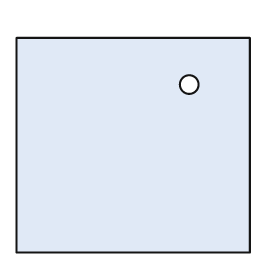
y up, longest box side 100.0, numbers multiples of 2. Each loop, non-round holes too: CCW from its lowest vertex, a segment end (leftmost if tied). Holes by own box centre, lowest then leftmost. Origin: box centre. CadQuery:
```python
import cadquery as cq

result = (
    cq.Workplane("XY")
    .moveTo(-50.0, -46.0)
    .lineTo(50.0, -46.0)
    .lineTo(50.0, 46.0)
    .lineTo(-50.0, 46.0)
    .close()
    .moveTo(24.0, 26.0)
    .circle(4.0)
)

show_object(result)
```